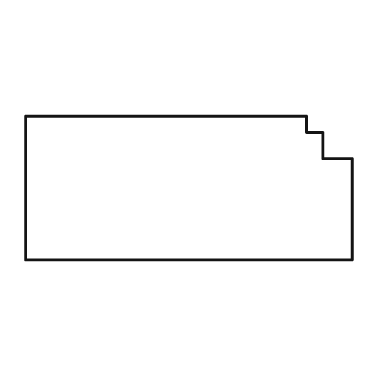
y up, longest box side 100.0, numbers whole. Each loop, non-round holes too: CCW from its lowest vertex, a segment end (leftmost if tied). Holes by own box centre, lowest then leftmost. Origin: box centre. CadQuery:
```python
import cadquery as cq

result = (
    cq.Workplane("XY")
    .moveTo(-50.0, -22.0)
    .lineTo(50.0, -22.0)
    .lineTo(50.0, 9.0)
    .lineTo(41.0, 9.0)
    .lineTo(41.0, 17.0)
    .lineTo(36.0, 17.0)
    .lineTo(36.0, 22.0)
    .lineTo(-50.0, 22.0)
    .close()
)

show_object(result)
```